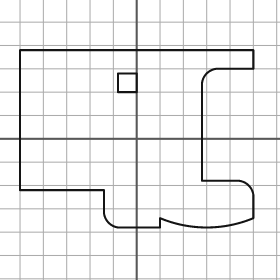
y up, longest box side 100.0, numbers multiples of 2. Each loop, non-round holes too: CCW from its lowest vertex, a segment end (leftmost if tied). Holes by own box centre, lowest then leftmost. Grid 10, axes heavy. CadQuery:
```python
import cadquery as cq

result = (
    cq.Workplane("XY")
    .moveTo(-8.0, -38.0)
    .lineTo(10.0, -38.0)
    .lineTo(10.0, -34.0)
    .threePointArc((30.0, -38.0), (50.0, -34.0))
    .lineTo(50.0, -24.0)
    .threePointArc((48.0, -20.0), (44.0, -18.0))
    .lineTo(28.0, -18.0)
    .lineTo(28.0, 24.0)
    .threePointArc((30.0, 28.0), (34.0, 30.0))
    .lineTo(50.0, 30.0)
    .lineTo(50.0, 38.0)
    .lineTo(-50.0, 38.0)
    .lineTo(-50.0, -22.0)
    .lineTo(-14.0, -22.0)
    .lineTo(-14.0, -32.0)
    .threePointArc((-12.0, -36.0), (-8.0, -38.0))
    .close()
    .moveTo(-8.0, 20.0)
    .lineTo(0.0, 20.0)
    .lineTo(0.0, 28.0)
    .lineTo(-8.0, 28.0)
    .close()
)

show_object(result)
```